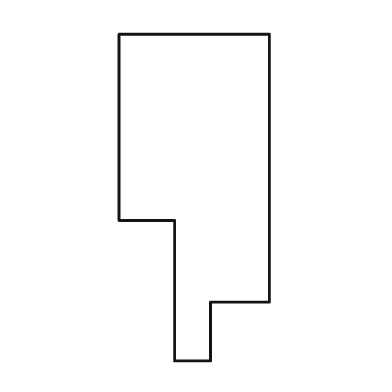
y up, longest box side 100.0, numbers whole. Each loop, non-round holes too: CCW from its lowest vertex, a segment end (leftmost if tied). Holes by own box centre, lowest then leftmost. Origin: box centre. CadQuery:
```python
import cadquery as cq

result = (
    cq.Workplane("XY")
    .moveTo(-6.0, -50.0)
    .lineTo(5.0, -50.0)
    .lineTo(5.0, -32.0)
    .lineTo(23.0, -32.0)
    .lineTo(23.0, 50.0)
    .lineTo(-23.0, 50.0)
    .lineTo(-23.0, -7.0)
    .lineTo(-6.0, -7.0)
    .close()
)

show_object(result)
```